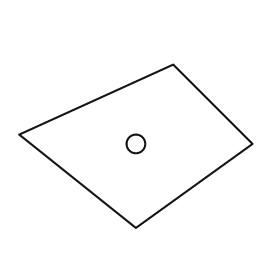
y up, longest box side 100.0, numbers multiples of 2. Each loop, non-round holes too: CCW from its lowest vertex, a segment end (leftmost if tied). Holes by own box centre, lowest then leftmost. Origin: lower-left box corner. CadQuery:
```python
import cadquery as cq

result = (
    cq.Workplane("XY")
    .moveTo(50.0, 0.0)
    .lineTo(100.0, 36.0)
    .lineTo(66.0, 70.0)
    .lineTo(0.0, 40.0)
    .close()
    .moveTo(50.0, 36.0)
    .circle(4.0)
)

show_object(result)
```